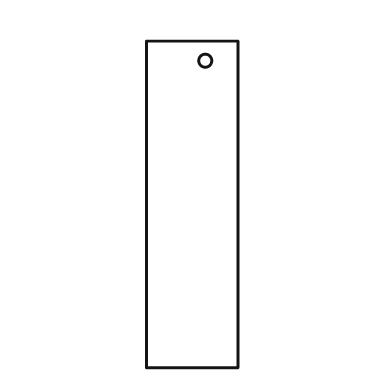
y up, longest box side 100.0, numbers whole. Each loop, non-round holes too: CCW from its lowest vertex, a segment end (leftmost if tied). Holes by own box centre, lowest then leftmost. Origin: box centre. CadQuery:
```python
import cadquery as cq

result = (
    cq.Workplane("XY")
    .moveTo(-14.0, -50.0)
    .lineTo(14.0, -50.0)
    .lineTo(14.0, 50.0)
    .lineTo(-14.0, 50.0)
    .close()
    .moveTo(4.0, 44.0)
    .circle(2.0)
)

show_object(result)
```